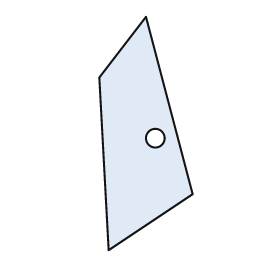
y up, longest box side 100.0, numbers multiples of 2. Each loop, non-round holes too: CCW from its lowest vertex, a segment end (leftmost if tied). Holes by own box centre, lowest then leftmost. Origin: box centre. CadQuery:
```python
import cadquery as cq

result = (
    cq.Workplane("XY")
    .moveTo(-16.0, -50.0)
    .lineTo(20.0, -26.0)
    .lineTo(0.0, 50.0)
    .lineTo(-20.0, 24.0)
    .close()
    .moveTo(4.0, -2.0)
    .circle(4.0)
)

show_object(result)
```